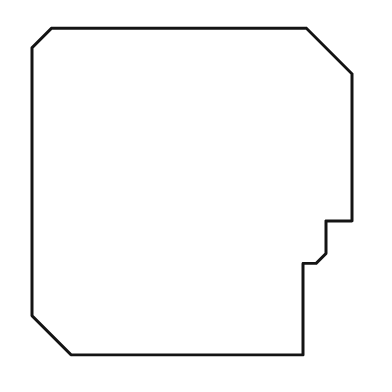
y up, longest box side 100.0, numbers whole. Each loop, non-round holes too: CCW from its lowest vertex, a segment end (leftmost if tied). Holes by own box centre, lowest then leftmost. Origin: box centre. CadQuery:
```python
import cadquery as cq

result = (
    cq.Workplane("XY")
    .moveTo(-37.0, -50.0)
    .lineTo(34.0, -50.0)
    .lineTo(34.0, -22.0)
    .lineTo(38.0, -22.0)
    .lineTo(41.0, -19.0)
    .lineTo(41.0, -9.0)
    .lineTo(49.0, -9.0)
    .lineTo(49.0, 36.0)
    .lineTo(35.0, 50.0)
    .lineTo(-43.0, 50.0)
    .lineTo(-49.0, 44.0)
    .lineTo(-49.0, -38.0)
    .close()
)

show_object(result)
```